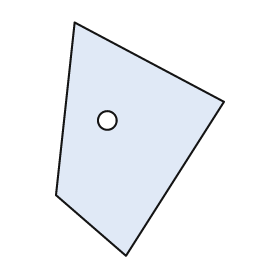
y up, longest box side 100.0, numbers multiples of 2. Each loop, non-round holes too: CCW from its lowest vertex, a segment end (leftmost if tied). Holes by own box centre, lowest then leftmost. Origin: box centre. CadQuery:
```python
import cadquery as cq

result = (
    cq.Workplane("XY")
    .moveTo(-6.0, -50.0)
    .lineTo(36.0, 16.0)
    .lineTo(-28.0, 50.0)
    .lineTo(-36.0, -24.0)
    .close()
    .moveTo(-14.0, 8.0)
    .circle(4.0)
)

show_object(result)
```